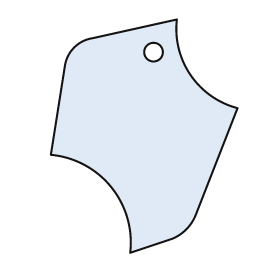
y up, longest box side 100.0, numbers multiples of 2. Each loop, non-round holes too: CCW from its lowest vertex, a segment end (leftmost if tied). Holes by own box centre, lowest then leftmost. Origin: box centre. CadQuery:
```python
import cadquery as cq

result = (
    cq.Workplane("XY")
    .moveTo(-6.0, -50.0)
    .lineTo(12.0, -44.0)
    .threePointArc((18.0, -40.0), (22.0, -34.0))
    .lineTo(40.0, 12.0)
    .threePointArc((20.0, 26.0), (14.0, 50.0))
    .lineTo(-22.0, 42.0)
    .threePointArc((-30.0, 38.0), (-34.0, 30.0))
    .lineTo(-40.0, -8.0)
    .threePointArc((-14.0, -22.0), (-6.0, -50.0))
    .close()
    .moveTo(4.0, 36.0)
    .circle(4.0)
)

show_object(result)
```